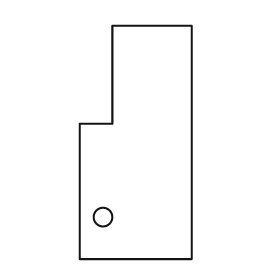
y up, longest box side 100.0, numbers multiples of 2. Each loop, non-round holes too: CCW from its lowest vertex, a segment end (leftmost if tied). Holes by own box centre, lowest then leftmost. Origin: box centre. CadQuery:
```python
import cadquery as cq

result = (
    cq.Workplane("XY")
    .moveTo(-24.0, -50.0)
    .lineTo(24.0, -50.0)
    .lineTo(24.0, 50.0)
    .lineTo(-10.0, 50.0)
    .lineTo(-10.0, 8.0)
    .lineTo(-24.0, 8.0)
    .close()
    .moveTo(-14.0, -32.0)
    .circle(4.0)
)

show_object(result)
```